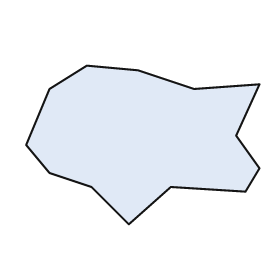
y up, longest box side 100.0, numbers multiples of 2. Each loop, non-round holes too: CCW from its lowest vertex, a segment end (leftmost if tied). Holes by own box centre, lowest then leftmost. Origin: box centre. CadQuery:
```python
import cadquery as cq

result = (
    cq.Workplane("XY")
    .moveTo(-6.0, -34.0)
    .lineTo(12.0, -18.0)
    .lineTo(44.0, -20.0)
    .lineTo(50.0, -10.0)
    .lineTo(40.0, 4.0)
    .lineTo(50.0, 26.0)
    .lineTo(22.0, 24.0)
    .lineTo(-2.0, 32.0)
    .lineTo(-24.0, 34.0)
    .lineTo(-40.0, 24.0)
    .lineTo(-50.0, 0.0)
    .lineTo(-40.0, -12.0)
    .lineTo(-22.0, -18.0)
    .close()
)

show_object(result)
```